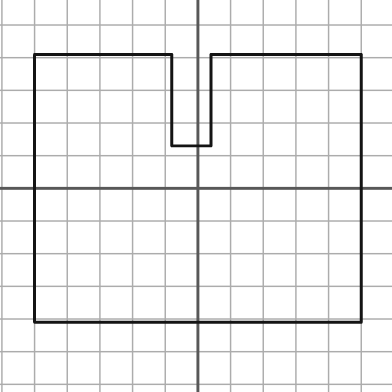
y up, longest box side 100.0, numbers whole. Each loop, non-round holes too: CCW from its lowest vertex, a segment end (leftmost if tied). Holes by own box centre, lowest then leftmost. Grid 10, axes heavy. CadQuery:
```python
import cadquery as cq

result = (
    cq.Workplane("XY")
    .moveTo(-50.0, -41.0)
    .lineTo(50.0, -41.0)
    .lineTo(50.0, 41.0)
    .lineTo(4.0, 41.0)
    .lineTo(4.0, 13.0)
    .lineTo(-8.0, 13.0)
    .lineTo(-8.0, 41.0)
    .lineTo(-50.0, 41.0)
    .close()
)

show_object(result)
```